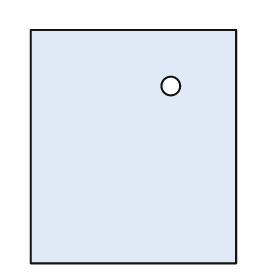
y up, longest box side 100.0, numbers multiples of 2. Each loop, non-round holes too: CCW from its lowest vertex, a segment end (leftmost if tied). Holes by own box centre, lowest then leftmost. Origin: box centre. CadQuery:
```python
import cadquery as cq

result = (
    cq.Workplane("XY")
    .moveTo(-44.0, -50.0)
    .lineTo(44.0, -50.0)
    .lineTo(44.0, 50.0)
    .lineTo(-44.0, 50.0)
    .close()
    .moveTo(16.0, 26.0)
    .circle(4.0)
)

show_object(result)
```